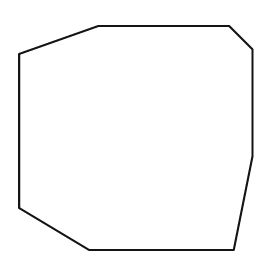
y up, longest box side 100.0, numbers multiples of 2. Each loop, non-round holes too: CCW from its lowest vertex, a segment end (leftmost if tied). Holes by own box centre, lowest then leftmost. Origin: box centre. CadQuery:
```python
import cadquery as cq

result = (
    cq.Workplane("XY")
    .moveTo(-20.0, -48.0)
    .lineTo(42.0, -48.0)
    .lineTo(50.0, -8.0)
    .lineTo(50.0, 38.0)
    .lineTo(40.0, 48.0)
    .lineTo(-16.0, 48.0)
    .lineTo(-50.0, 36.0)
    .lineTo(-50.0, -30.0)
    .close()
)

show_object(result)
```